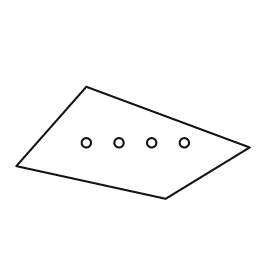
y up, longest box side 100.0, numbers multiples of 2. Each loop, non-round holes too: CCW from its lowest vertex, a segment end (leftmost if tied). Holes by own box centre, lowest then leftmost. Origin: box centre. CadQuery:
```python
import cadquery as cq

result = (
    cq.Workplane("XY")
    .moveTo(14.0, -24.0)
    .lineTo(50.0, -2.0)
    .lineTo(-20.0, 24.0)
    .lineTo(-50.0, -10.0)
    .close()
    .moveTo(-20.0, 0.0)
    .circle(2.0)
    .moveTo(-6.0, 0.0)
    .circle(2.0)
    .moveTo(8.0, 0.0)
    .circle(2.0)
    .moveTo(22.0, 0.0)
    .circle(2.0)
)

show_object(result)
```